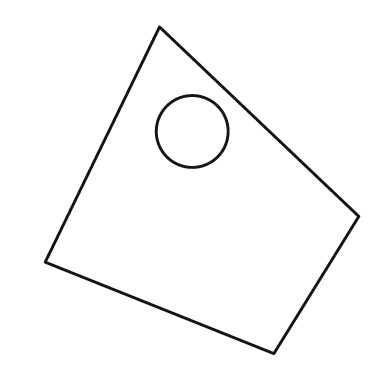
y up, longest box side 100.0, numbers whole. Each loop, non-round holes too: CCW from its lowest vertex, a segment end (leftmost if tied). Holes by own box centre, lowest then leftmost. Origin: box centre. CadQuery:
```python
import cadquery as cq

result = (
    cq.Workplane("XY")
    .moveTo(22.0, -50.0)
    .lineTo(48.0, -8.0)
    .lineTo(-13.0, 50.0)
    .lineTo(-48.0, -22.0)
    .close()
    .moveTo(-3.0, 18.0)
    .circle(11.0)
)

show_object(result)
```